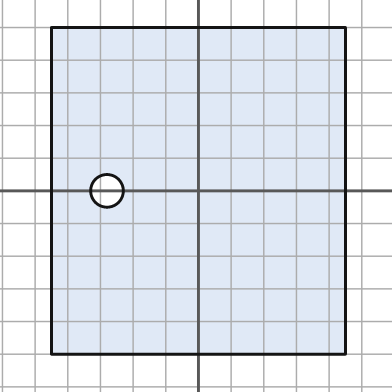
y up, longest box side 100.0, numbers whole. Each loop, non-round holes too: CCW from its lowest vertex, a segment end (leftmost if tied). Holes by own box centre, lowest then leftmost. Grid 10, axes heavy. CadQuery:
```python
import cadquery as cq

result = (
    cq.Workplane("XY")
    .moveTo(-45.0, -50.0)
    .lineTo(45.0, -50.0)
    .lineTo(45.0, 50.0)
    .lineTo(-45.0, 50.0)
    .close()
    .moveTo(-28.0, 0.0)
    .circle(5.0)
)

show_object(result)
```